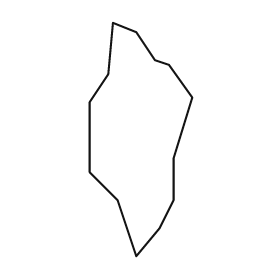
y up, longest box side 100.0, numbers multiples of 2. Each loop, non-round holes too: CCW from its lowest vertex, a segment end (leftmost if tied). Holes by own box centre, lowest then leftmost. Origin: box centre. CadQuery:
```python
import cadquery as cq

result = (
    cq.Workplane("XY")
    .moveTo(-2.0, -50.0)
    .lineTo(8.0, -38.0)
    .lineTo(14.0, -26.0)
    .lineTo(14.0, -8.0)
    .lineTo(22.0, 18.0)
    .lineTo(12.0, 32.0)
    .lineTo(6.0, 34.0)
    .lineTo(-2.0, 46.0)
    .lineTo(-12.0, 50.0)
    .lineTo(-14.0, 28.0)
    .lineTo(-22.0, 16.0)
    .lineTo(-22.0, -14.0)
    .lineTo(-10.0, -26.0)
    .close()
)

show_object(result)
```